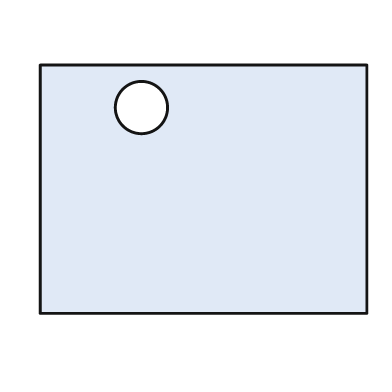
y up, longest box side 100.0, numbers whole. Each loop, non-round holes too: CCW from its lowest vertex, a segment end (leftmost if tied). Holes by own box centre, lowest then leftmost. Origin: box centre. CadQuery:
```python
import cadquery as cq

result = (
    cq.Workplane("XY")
    .moveTo(-50.0, -38.0)
    .lineTo(50.0, -38.0)
    .lineTo(50.0, 38.0)
    .lineTo(-50.0, 38.0)
    .close()
    .moveTo(-19.0, 25.0)
    .circle(8.0)
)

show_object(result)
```